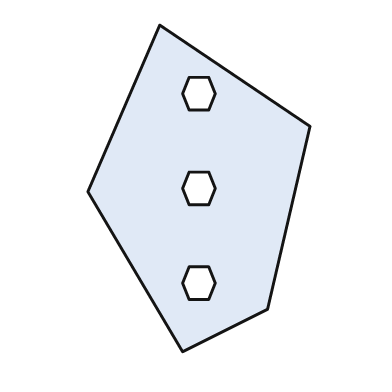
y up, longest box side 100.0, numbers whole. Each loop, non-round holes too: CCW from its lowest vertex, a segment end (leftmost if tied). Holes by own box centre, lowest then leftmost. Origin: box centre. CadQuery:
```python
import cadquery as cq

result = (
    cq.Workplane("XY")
    .moveTo(-5.0, -50.0)
    .lineTo(21.0, -37.0)
    .lineTo(34.0, 19.0)
    .lineTo(-12.0, 50.0)
    .lineTo(-34.0, -1.0)
    .close()
    .moveTo(-3.0, -34.0)
    .lineTo(3.0, -34.0)
    .lineTo(5.0, -29.0)
    .lineTo(3.0, -24.0)
    .lineTo(-3.0, -24.0)
    .lineTo(-5.0, -29.0)
    .close()
    .moveTo(-3.0, -5.0)
    .lineTo(3.0, -5.0)
    .lineTo(5.0, 0.0)
    .lineTo(3.0, 5.0)
    .lineTo(-3.0, 5.0)
    .lineTo(-5.0, 0.0)
    .close()
    .moveTo(-3.0, 24.0)
    .lineTo(3.0, 24.0)
    .lineTo(5.0, 29.0)
    .lineTo(3.0, 34.0)
    .lineTo(-3.0, 34.0)
    .lineTo(-5.0, 29.0)
    .close()
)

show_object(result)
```